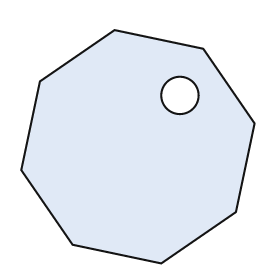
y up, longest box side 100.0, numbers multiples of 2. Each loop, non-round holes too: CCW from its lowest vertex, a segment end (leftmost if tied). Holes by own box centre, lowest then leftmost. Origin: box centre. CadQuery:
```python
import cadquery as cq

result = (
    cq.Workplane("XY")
    .moveTo(10.0, -50.0)
    .lineTo(42.0, -28.0)
    .lineTo(50.0, 10.0)
    .lineTo(28.0, 42.0)
    .lineTo(-10.0, 50.0)
    .lineTo(-42.0, 28.0)
    .lineTo(-50.0, -10.0)
    .lineTo(-28.0, -42.0)
    .close()
    .moveTo(18.0, 22.0)
    .circle(8.0)
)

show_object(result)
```